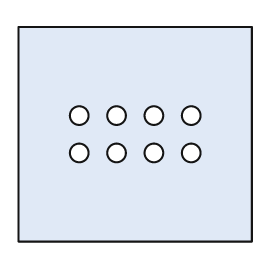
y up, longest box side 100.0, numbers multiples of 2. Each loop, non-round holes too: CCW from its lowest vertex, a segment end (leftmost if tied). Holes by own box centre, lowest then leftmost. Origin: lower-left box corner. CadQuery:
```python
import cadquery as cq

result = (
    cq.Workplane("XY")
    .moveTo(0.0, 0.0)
    .lineTo(100.0, 0.0)
    .lineTo(100.0, 92.0)
    .lineTo(0.0, 92.0)
    .close()
    .moveTo(26.0, 38.0)
    .circle(4.0)
    .moveTo(42.0, 38.0)
    .circle(4.0)
    .moveTo(58.0, 38.0)
    .circle(4.0)
    .moveTo(74.0, 38.0)
    .circle(4.0)
    .moveTo(26.0, 54.0)
    .circle(4.0)
    .moveTo(42.0, 54.0)
    .circle(4.0)
    .moveTo(58.0, 54.0)
    .circle(4.0)
    .moveTo(74.0, 54.0)
    .circle(4.0)
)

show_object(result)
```